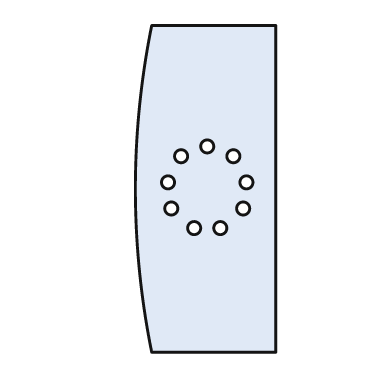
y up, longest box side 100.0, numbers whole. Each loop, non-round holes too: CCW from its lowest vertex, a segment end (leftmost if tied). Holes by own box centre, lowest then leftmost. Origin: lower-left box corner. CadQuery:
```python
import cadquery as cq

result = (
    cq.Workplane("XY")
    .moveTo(5.0, 0.0)
    .lineTo(43.0, 0.0)
    .lineTo(43.0, 100.0)
    .lineTo(5.0, 100.0)
    .threePointArc((0.0, 50.0), (5.0, 0.0))
    .close()
    .moveTo(18.0, 38.0)
    .circle(2.0)
    .moveTo(26.0, 38.0)
    .circle(2.0)
    .moveTo(11.0, 44.0)
    .circle(2.0)
    .moveTo(33.0, 44.0)
    .circle(2.0)
    .moveTo(10.0, 52.0)
    .circle(2.0)
    .moveTo(34.0, 52.0)
    .circle(2.0)
    .moveTo(14.0, 60.0)
    .circle(2.0)
    .moveTo(30.0, 60.0)
    .circle(2.0)
    .moveTo(22.0, 63.0)
    .circle(2.0)
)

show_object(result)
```